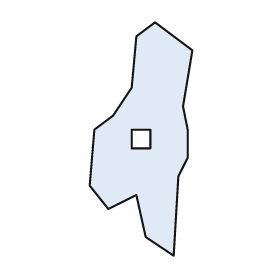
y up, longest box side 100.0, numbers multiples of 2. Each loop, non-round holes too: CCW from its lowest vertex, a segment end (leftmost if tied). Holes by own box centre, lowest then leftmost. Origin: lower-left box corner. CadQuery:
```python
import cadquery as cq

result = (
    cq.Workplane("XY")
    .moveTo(36.0, 0.0)
    .lineTo(38.0, 34.0)
    .lineTo(42.0, 42.0)
    .lineTo(42.0, 54.0)
    .lineTo(40.0, 64.0)
    .lineTo(44.0, 88.0)
    .lineTo(28.0, 100.0)
    .lineTo(20.0, 94.0)
    .lineTo(18.0, 72.0)
    .lineTo(10.0, 60.0)
    .lineTo(2.0, 54.0)
    .lineTo(0.0, 30.0)
    .lineTo(8.0, 20.0)
    .lineTo(20.0, 26.0)
    .lineTo(24.0, 8.0)
    .close()
    .moveTo(18.0, 46.0)
    .lineTo(26.0, 46.0)
    .lineTo(26.0, 54.0)
    .lineTo(18.0, 54.0)
    .close()
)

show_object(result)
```